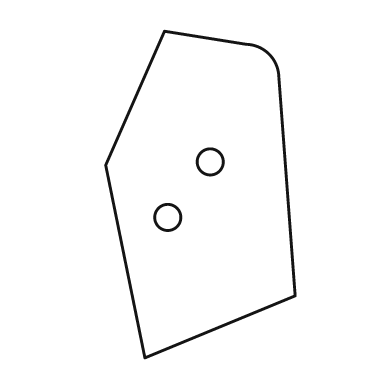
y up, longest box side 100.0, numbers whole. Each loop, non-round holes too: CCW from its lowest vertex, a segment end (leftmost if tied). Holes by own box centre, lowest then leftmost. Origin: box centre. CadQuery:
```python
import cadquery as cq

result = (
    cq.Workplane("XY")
    .moveTo(-17.0, -50.0)
    .lineTo(29.0, -31.0)
    .lineTo(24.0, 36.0)
    .threePointArc((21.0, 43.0), (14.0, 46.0))
    .lineTo(-11.0, 50.0)
    .lineTo(-29.0, 9.0)
    .close()
    .moveTo(-10.0, -7.0)
    .circle(4.0)
    .moveTo(3.0, 10.0)
    .circle(4.0)
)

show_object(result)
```